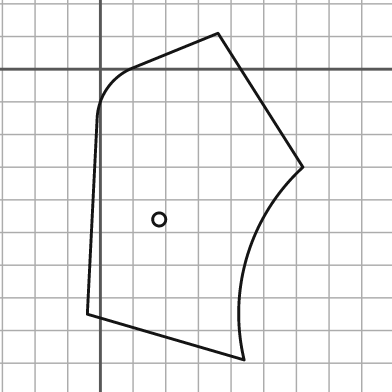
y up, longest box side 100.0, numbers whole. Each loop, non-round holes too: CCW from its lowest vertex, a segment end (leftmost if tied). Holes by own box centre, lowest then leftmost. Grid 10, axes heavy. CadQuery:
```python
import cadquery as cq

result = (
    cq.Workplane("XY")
    .moveTo(44.0, -89.0)
    .threePointArc((45.0, -57.0), (62.0, -30.0))
    .lineTo(36.0, 11.0)
    .lineTo(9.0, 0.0)
    .threePointArc((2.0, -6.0), (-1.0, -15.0))
    .lineTo(-4.0, -75.0)
    .close()
    .moveTo(18.0, -46.0)
    .circle(2.0)
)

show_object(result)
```